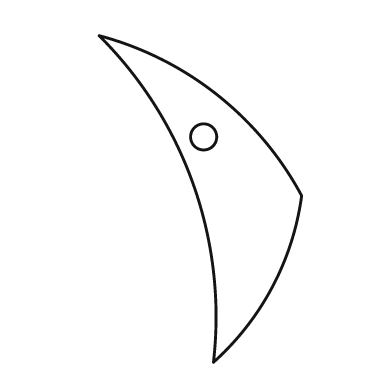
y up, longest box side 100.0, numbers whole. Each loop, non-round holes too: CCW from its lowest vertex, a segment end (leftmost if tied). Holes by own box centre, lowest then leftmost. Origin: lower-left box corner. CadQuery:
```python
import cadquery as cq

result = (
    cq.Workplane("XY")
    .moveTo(35.0, 0.0)
    .threePointArc((53.0, 23.0), (62.0, 51.0))
    .threePointArc((36.0, 82.0), (0.0, 100.0))
    .threePointArc((29.0, 54.0), (35.0, 0.0))
    .close()
    .moveTo(32.0, 69.0)
    .circle(4.0)
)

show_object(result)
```